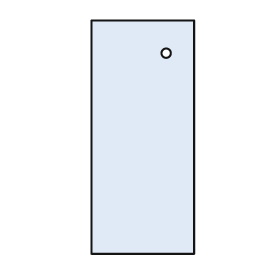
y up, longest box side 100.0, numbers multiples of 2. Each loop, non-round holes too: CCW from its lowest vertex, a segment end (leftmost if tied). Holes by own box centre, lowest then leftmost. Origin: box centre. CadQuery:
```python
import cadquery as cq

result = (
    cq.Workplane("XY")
    .moveTo(-22.0, -50.0)
    .lineTo(22.0, -50.0)
    .lineTo(22.0, 50.0)
    .lineTo(-22.0, 50.0)
    .close()
    .moveTo(10.0, 36.0)
    .circle(2.0)
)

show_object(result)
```